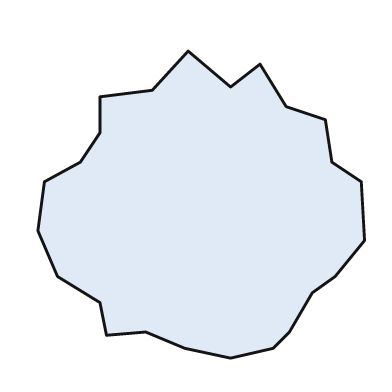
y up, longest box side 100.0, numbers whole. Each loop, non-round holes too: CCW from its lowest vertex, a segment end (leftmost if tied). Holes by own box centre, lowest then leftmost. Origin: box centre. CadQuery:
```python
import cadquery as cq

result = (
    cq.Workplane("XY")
    .moveTo(9.0, -47.0)
    .lineTo(22.0, -44.0)
    .lineTo(27.0, -39.0)
    .lineTo(34.0, -27.0)
    .lineTo(41.0, -22.0)
    .lineTo(50.0, -11.0)
    .lineTo(49.0, 7.0)
    .lineTo(40.0, 13.0)
    .lineTo(38.0, 26.0)
    .lineTo(26.0, 30.0)
    .lineTo(18.0, 43.0)
    .lineTo(9.0, 36.0)
    .lineTo(-4.0, 47.0)
    .lineTo(-15.0, 35.0)
    .lineTo(-31.0, 33.0)
    .lineTo(-31.0, 22.0)
    .lineTo(-37.0, 13.0)
    .lineTo(-48.0, 7.0)
    .lineTo(-50.0, -8.0)
    .lineTo(-44.0, -22.0)
    .lineTo(-31.0, -30.0)
    .lineTo(-29.0, -40.0)
    .lineTo(-17.0, -39.0)
    .lineTo(-5.0, -44.0)
    .close()
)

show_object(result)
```